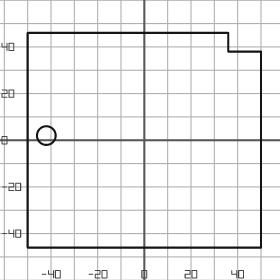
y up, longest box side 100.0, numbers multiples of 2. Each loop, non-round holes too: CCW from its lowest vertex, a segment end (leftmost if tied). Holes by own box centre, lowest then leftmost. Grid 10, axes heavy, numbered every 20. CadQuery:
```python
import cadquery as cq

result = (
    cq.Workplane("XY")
    .moveTo(-50.0, -46.0)
    .lineTo(50.0, -46.0)
    .lineTo(50.0, 38.0)
    .lineTo(36.0, 38.0)
    .lineTo(36.0, 46.0)
    .lineTo(-50.0, 46.0)
    .close()
    .moveTo(-42.0, 2.0)
    .circle(4.0)
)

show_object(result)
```